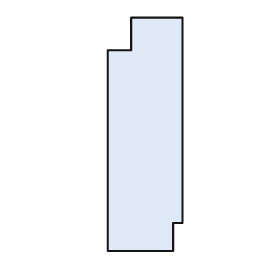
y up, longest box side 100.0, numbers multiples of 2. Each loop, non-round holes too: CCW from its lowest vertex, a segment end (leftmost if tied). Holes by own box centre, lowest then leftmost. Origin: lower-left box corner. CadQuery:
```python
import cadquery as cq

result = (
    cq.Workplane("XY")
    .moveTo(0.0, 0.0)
    .lineTo(28.0, 0.0)
    .lineTo(28.0, 12.0)
    .lineTo(32.0, 12.0)
    .lineTo(32.0, 100.0)
    .lineTo(10.0, 100.0)
    .lineTo(10.0, 86.0)
    .lineTo(0.0, 86.0)
    .close()
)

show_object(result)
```